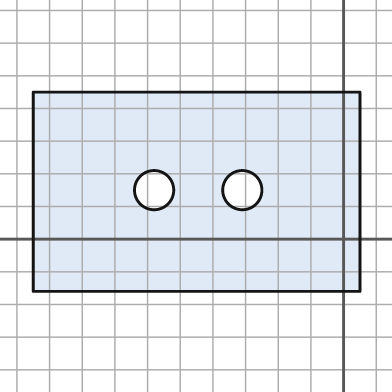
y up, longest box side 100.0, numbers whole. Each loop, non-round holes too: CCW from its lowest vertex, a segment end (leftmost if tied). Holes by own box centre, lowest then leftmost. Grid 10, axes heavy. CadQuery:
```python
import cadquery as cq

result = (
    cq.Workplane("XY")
    .moveTo(-95.0, -16.0)
    .lineTo(5.0, -16.0)
    .lineTo(5.0, 45.0)
    .lineTo(-95.0, 45.0)
    .close()
    .moveTo(-58.0, 15.0)
    .circle(6.0)
    .moveTo(-31.0, 15.0)
    .circle(6.0)
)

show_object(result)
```